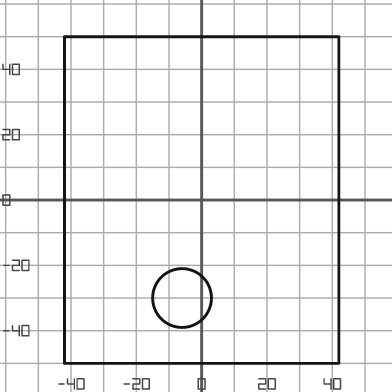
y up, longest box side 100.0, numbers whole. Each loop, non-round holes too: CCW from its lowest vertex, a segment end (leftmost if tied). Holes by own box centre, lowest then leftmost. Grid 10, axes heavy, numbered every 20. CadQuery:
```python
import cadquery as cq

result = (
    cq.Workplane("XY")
    .moveTo(-42.0, -50.0)
    .lineTo(42.0, -50.0)
    .lineTo(42.0, 50.0)
    .lineTo(-42.0, 50.0)
    .close()
    .moveTo(-6.0, -30.0)
    .circle(9.0)
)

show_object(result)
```